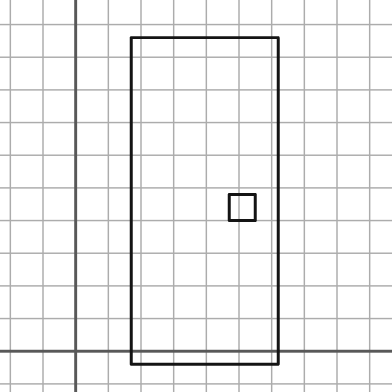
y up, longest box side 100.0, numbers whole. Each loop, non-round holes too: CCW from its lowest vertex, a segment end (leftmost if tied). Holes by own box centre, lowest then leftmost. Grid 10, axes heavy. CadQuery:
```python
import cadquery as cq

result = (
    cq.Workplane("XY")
    .moveTo(17.0, -4.0)
    .lineTo(62.0, -4.0)
    .lineTo(62.0, 96.0)
    .lineTo(17.0, 96.0)
    .close()
    .moveTo(47.0, 40.0)
    .lineTo(55.0, 40.0)
    .lineTo(55.0, 48.0)
    .lineTo(47.0, 48.0)
    .close()
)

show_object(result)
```